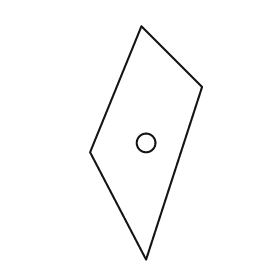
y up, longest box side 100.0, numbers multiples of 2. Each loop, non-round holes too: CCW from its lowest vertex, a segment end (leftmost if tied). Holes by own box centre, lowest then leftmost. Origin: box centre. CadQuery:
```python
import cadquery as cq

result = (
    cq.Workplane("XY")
    .moveTo(0.0, -50.0)
    .lineTo(24.0, 24.0)
    .lineTo(-2.0, 50.0)
    .lineTo(-24.0, -4.0)
    .close()
    .moveTo(0.0, 0.0)
    .circle(4.0)
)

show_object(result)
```